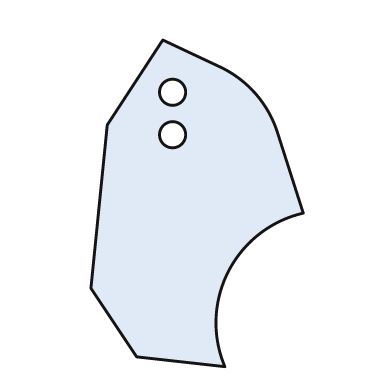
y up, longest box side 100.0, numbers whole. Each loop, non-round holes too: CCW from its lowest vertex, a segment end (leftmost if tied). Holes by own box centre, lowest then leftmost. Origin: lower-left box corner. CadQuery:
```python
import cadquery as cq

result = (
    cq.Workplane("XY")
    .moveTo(41.0, 0.0)
    .threePointArc((42.0, 29.0), (65.0, 47.0))
    .lineTo(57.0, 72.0)
    .threePointArc((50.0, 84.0), (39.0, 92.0))
    .lineTo(22.0, 100.0)
    .lineTo(5.0, 74.0)
    .lineTo(0.0, 24.0)
    .lineTo(14.0, 3.0)
    .close()
    .moveTo(25.0, 71.0)
    .circle(4.0)
    .moveTo(25.0, 84.0)
    .circle(4.0)
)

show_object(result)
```